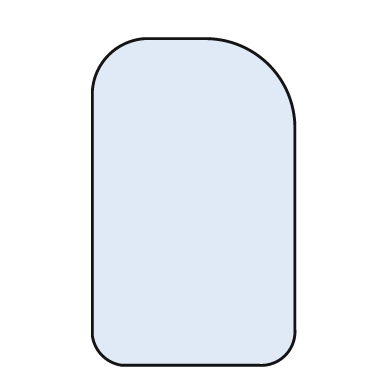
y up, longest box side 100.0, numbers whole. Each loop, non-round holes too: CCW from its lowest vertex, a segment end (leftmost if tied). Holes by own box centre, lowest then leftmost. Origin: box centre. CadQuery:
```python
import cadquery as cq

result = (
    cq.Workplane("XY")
    .moveTo(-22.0, -50.0)
    .lineTo(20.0, -50.0)
    .threePointArc((28.0, -47.0), (31.0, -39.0))
    .lineTo(31.0, 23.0)
    .threePointArc((23.0, 42.0), (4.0, 50.0))
    .lineTo(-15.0, 50.0)
    .threePointArc((-26.0, 45.0), (-31.0, 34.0))
    .lineTo(-31.0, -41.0)
    .threePointArc((-28.0, -47.0), (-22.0, -50.0))
    .close()
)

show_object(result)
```